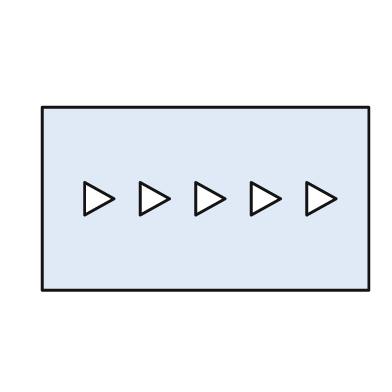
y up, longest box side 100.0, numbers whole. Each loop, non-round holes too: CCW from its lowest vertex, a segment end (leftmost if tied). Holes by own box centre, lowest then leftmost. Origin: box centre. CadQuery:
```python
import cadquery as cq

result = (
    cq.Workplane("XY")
    .moveTo(-50.0, -28.0)
    .lineTo(50.0, -28.0)
    .lineTo(50.0, 28.0)
    .lineTo(-50.0, 28.0)
    .close()
    .moveTo(-37.0, -5.0)
    .lineTo(-28.0, 0.0)
    .lineTo(-37.0, 5.0)
    .close()
    .moveTo(-20.0, -5.0)
    .lineTo(-11.0, 0.0)
    .lineTo(-20.0, 5.0)
    .close()
    .moveTo(-3.0, -5.0)
    .lineTo(6.0, 0.0)
    .lineTo(-3.0, 5.0)
    .close()
    .moveTo(14.0, -5.0)
    .lineTo(23.0, 0.0)
    .lineTo(14.0, 5.0)
    .close()
    .moveTo(31.0, -5.0)
    .lineTo(40.0, 0.0)
    .lineTo(31.0, 5.0)
    .close()
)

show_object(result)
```